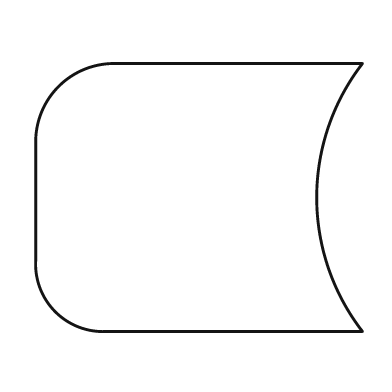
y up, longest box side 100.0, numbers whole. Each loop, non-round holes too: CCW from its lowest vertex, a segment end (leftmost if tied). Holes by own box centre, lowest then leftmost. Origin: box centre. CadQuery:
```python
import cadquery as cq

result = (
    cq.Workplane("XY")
    .moveTo(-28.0, -41.0)
    .lineTo(50.0, -41.0)
    .threePointArc((36.0, 0.0), (50.0, 41.0))
    .lineTo(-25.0, 41.0)
    .threePointArc((-43.0, 34.0), (-50.0, 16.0))
    .lineTo(-50.0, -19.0)
    .threePointArc((-44.0, -35.0), (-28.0, -41.0))
    .close()
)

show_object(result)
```